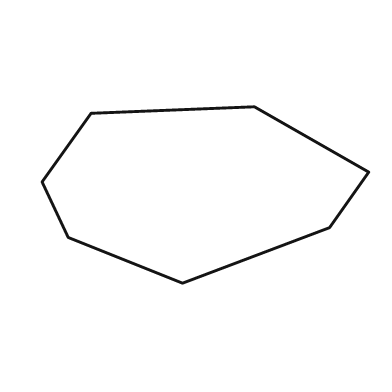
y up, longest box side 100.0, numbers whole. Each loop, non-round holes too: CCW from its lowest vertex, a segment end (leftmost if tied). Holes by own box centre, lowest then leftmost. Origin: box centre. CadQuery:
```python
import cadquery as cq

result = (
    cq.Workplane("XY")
    .moveTo(-7.0, -27.0)
    .lineTo(38.0, -10.0)
    .lineTo(50.0, 7.0)
    .lineTo(15.0, 27.0)
    .lineTo(-35.0, 25.0)
    .lineTo(-50.0, 4.0)
    .lineTo(-42.0, -13.0)
    .close()
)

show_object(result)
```